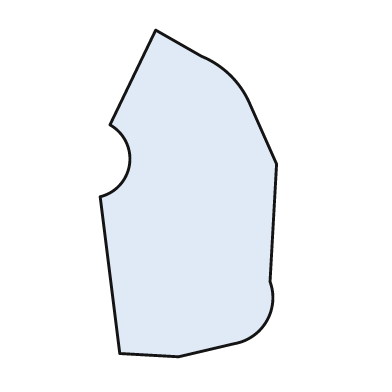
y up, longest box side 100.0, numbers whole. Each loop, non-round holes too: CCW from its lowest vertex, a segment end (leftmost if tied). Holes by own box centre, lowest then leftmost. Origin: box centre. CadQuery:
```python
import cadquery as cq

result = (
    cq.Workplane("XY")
    .moveTo(-3.0, -50.0)
    .lineTo(14.0, -46.0)
    .threePointArc((24.0, -39.0), (25.0, -27.0))
    .lineTo(27.0, 9.0)
    .lineTo(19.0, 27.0)
    .threePointArc((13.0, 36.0), (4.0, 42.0))
    .lineTo(-10.0, 50.0)
    .lineTo(-24.0, 21.0)
    .threePointArc((-18.0, 9.0), (-27.0, -1.0))
    .lineTo(-21.0, -49.0)
    .close()
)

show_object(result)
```